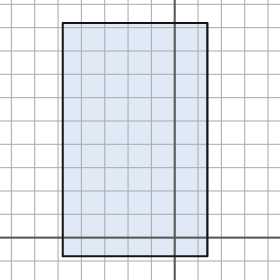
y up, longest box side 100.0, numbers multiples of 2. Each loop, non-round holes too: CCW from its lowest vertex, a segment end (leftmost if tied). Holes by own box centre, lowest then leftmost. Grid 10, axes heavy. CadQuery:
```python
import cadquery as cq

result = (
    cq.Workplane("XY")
    .moveTo(-48.0, -8.0)
    .lineTo(14.0, -8.0)
    .lineTo(14.0, 92.0)
    .lineTo(-48.0, 92.0)
    .close()
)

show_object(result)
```